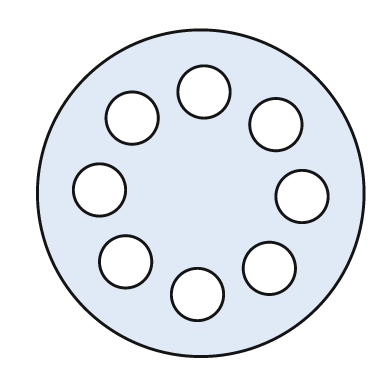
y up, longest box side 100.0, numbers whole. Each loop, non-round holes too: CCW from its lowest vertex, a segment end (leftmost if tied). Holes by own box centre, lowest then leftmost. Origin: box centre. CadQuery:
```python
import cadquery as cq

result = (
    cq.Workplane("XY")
    .moveTo(0.0, 0.0)
    .circle(50.0)
    .moveTo(-1.0, -31.0)
    .circle(8.0)
    .moveTo(21.0, -23.0)
    .circle(8.0)
    .moveTo(-23.0, -21.0)
    .circle(8.0)
    .moveTo(31.0, -1.0)
    .circle(8.0)
    .moveTo(-31.0, 1.0)
    .circle(8.0)
    .moveTo(23.0, 21.0)
    .circle(8.0)
    .moveTo(-21.0, 23.0)
    .circle(8.0)
    .moveTo(1.0, 31.0)
    .circle(8.0)
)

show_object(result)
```